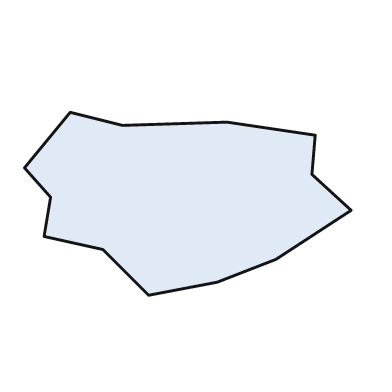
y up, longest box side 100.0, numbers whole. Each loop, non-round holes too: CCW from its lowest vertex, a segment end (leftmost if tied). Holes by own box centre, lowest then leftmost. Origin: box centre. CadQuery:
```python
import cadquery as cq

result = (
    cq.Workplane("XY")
    .moveTo(-12.0, -28.0)
    .lineTo(9.0, -24.0)
    .lineTo(27.0, -17.0)
    .lineTo(50.0, -2.0)
    .lineTo(38.0, 9.0)
    .lineTo(39.0, 21.0)
    .lineTo(12.0, 25.0)
    .lineTo(-20.0, 24.0)
    .lineTo(-36.0, 28.0)
    .lineTo(-50.0, 11.0)
    .lineTo(-42.0, 2.0)
    .lineTo(-44.0, -10.0)
    .lineTo(-26.0, -14.0)
    .close()
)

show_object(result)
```